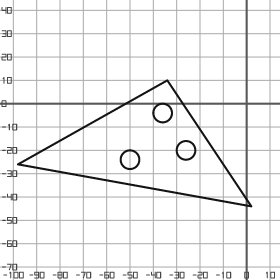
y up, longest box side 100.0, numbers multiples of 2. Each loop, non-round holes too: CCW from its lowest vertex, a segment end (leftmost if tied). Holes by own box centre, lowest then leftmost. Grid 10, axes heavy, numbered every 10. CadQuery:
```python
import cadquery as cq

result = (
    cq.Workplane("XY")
    .moveTo(2.0, -44.0)
    .lineTo(-34.0, 10.0)
    .lineTo(-98.0, -26.0)
    .close()
    .moveTo(-50.0, -24.0)
    .circle(4.0)
    .moveTo(-26.0, -20.0)
    .circle(4.0)
    .moveTo(-36.0, -4.0)
    .circle(4.0)
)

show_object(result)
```